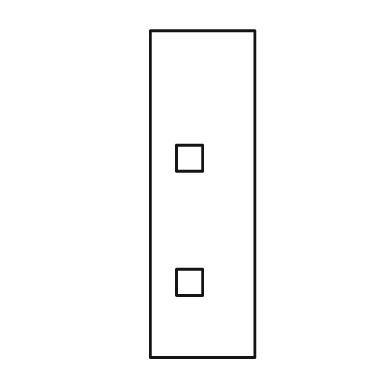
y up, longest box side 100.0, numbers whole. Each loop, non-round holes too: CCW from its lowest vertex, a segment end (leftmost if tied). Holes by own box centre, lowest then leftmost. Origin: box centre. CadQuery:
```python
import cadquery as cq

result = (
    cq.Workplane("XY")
    .moveTo(-16.0, -50.0)
    .lineTo(16.0, -50.0)
    .lineTo(16.0, 50.0)
    .lineTo(-16.0, 50.0)
    .close()
    .moveTo(-8.0, -31.0)
    .lineTo(0.0, -31.0)
    .lineTo(0.0, -23.0)
    .lineTo(-8.0, -23.0)
    .close()
    .moveTo(-8.0, 7.0)
    .lineTo(0.0, 7.0)
    .lineTo(0.0, 15.0)
    .lineTo(-8.0, 15.0)
    .close()
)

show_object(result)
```